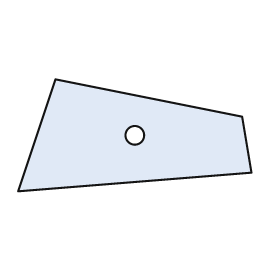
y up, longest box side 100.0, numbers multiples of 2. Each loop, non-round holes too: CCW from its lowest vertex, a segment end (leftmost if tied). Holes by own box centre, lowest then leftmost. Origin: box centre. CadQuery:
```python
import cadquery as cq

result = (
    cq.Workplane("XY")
    .moveTo(-50.0, -24.0)
    .lineTo(50.0, -16.0)
    .lineTo(46.0, 8.0)
    .lineTo(-34.0, 24.0)
    .close()
    .moveTo(0.0, 0.0)
    .circle(4.0)
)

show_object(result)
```